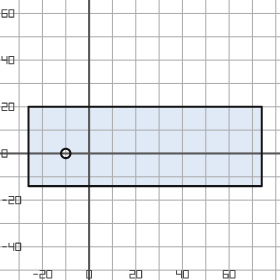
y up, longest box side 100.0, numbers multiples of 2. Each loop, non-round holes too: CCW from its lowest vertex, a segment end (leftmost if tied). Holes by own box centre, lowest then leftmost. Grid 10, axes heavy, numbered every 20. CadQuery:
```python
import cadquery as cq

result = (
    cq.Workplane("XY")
    .moveTo(-26.0, -14.0)
    .lineTo(74.0, -14.0)
    .lineTo(74.0, 20.0)
    .lineTo(-26.0, 20.0)
    .close()
    .moveTo(-10.0, 0.0)
    .circle(2.0)
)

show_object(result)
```